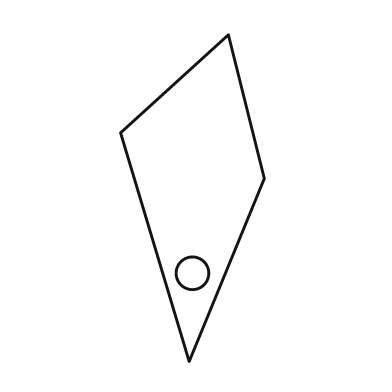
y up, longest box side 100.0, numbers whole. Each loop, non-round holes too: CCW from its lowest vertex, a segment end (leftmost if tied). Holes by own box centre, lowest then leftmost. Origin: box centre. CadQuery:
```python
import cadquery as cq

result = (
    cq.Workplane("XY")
    .moveTo(-1.0, -50.0)
    .lineTo(22.0, 6.0)
    .lineTo(11.0, 50.0)
    .lineTo(-22.0, 20.0)
    .close()
    .moveTo(0.0, -23.0)
    .circle(5.0)
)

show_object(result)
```